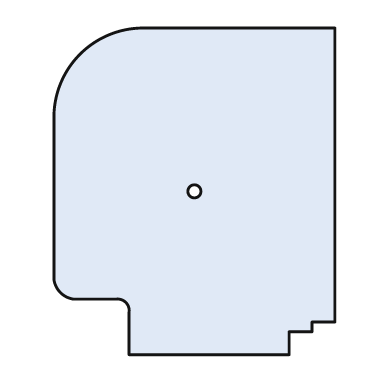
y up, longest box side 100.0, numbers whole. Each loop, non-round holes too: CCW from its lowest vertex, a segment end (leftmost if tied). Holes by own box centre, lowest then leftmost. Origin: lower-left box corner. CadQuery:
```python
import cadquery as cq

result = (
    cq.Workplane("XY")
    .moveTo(23.0, 0.0)
    .lineTo(72.0, 0.0)
    .lineTo(72.0, 7.0)
    .lineTo(79.0, 7.0)
    .lineTo(79.0, 10.0)
    .lineTo(86.0, 10.0)
    .lineTo(86.0, 100.0)
    .lineTo(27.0, 100.0)
    .threePointArc((8.0, 92.0), (0.0, 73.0))
    .lineTo(0.0, 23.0)
    .threePointArc((2.0, 19.0), (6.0, 17.0))
    .lineTo(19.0, 17.0)
    .threePointArc((22.0, 16.0), (23.0, 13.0))
    .close()
    .moveTo(43.0, 50.0)
    .circle(2.0)
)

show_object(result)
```